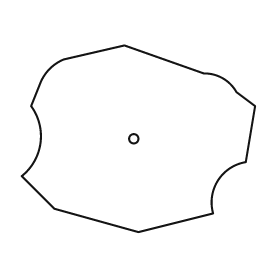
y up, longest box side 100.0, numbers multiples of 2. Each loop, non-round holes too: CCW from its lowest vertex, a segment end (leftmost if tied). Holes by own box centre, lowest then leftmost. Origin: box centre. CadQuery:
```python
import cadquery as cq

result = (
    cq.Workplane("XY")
    .moveTo(0.0, -40.0)
    .lineTo(32.0, -32.0)
    .threePointArc((34.0, -18.0), (46.0, -10.0))
    .lineTo(50.0, 14.0)
    .lineTo(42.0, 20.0)
    .threePointArc((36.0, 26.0), (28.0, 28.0))
    .lineTo(-6.0, 40.0)
    .lineTo(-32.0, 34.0)
    .threePointArc((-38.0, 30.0), (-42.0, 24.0))
    .lineTo(-46.0, 14.0)
    .threePointArc((-42.0, -2.0), (-50.0, -16.0))
    .lineTo(-36.0, -30.0)
    .close()
    .moveTo(-2.0, 0.0)
    .circle(2.0)
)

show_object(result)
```